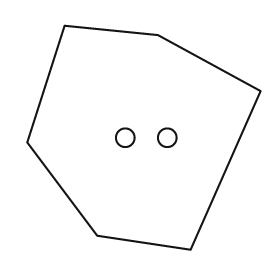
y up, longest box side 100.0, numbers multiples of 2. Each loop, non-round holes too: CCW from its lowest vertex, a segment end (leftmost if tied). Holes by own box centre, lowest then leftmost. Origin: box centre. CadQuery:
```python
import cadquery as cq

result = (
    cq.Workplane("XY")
    .moveTo(20.0, -48.0)
    .lineTo(50.0, 20.0)
    .lineTo(6.0, 44.0)
    .lineTo(-34.0, 48.0)
    .lineTo(-50.0, -2.0)
    .lineTo(-20.0, -42.0)
    .close()
    .moveTo(-8.0, 0.0)
    .circle(4.0)
    .moveTo(10.0, 0.0)
    .circle(4.0)
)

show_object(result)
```